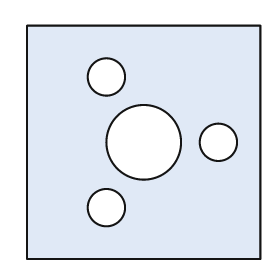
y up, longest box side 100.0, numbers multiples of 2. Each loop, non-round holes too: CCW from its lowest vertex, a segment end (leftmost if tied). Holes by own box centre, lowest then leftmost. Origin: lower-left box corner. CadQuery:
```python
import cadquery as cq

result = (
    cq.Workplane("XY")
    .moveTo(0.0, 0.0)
    .lineTo(100.0, 0.0)
    .lineTo(100.0, 100.0)
    .lineTo(0.0, 100.0)
    .close()
    .moveTo(34.0, 22.0)
    .circle(8.0)
    .moveTo(50.0, 50.0)
    .circle(16.0)
    .moveTo(82.0, 50.0)
    .circle(8.0)
    .moveTo(34.0, 78.0)
    .circle(8.0)
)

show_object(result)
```